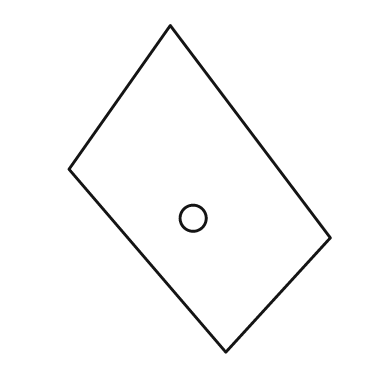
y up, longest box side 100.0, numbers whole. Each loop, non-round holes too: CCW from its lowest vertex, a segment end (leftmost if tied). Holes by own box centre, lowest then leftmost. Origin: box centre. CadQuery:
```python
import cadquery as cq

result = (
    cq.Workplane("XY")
    .moveTo(8.0, -50.0)
    .lineTo(40.0, -15.0)
    .lineTo(-9.0, 50.0)
    .lineTo(-40.0, 6.0)
    .close()
    .moveTo(-2.0, -9.0)
    .circle(4.0)
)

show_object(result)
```